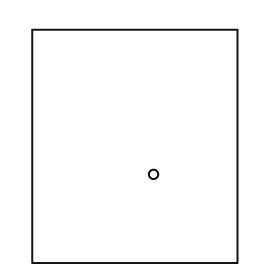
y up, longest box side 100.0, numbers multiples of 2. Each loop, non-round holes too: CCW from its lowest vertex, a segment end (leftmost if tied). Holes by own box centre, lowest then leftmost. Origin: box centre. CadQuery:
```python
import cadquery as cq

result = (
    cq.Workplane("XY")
    .moveTo(-44.0, -50.0)
    .lineTo(44.0, -50.0)
    .lineTo(44.0, 50.0)
    .lineTo(-44.0, 50.0)
    .close()
    .moveTo(8.0, -12.0)
    .circle(2.0)
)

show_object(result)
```